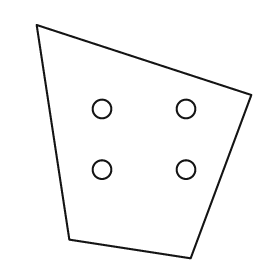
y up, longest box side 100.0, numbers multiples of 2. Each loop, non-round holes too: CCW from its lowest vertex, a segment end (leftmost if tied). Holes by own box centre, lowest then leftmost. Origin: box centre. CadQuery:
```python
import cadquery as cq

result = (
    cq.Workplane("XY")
    .moveTo(20.0, -50.0)
    .lineTo(46.0, 20.0)
    .lineTo(-46.0, 50.0)
    .lineTo(-32.0, -42.0)
    .close()
    .moveTo(-18.0, -12.0)
    .circle(4.0)
    .moveTo(18.0, -12.0)
    .circle(4.0)
    .moveTo(-18.0, 14.0)
    .circle(4.0)
    .moveTo(18.0, 14.0)
    .circle(4.0)
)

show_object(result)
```